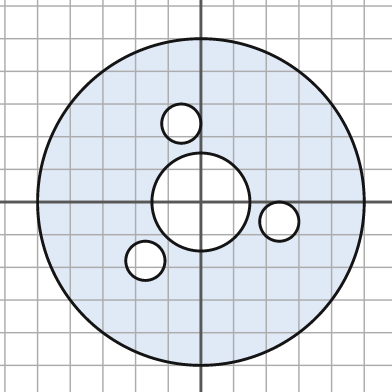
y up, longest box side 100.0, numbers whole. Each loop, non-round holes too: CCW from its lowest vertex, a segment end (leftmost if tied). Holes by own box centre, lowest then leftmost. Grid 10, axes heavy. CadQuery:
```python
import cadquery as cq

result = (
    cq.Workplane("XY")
    .moveTo(0.0, 0.0)
    .circle(50.0)
    .moveTo(-17.0, -18.0)
    .circle(6.0)
    .moveTo(24.0, -6.0)
    .circle(6.0)
    .moveTo(0.0, 0.0)
    .circle(15.0)
    .moveTo(-6.0, 24.0)
    .circle(6.0)
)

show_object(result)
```